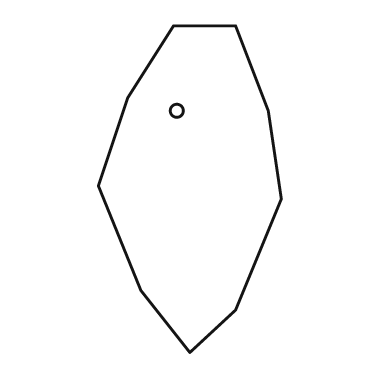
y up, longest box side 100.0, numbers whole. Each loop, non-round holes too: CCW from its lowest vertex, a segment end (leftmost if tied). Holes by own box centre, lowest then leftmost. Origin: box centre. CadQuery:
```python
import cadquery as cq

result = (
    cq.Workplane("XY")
    .moveTo(0.0, -50.0)
    .lineTo(14.0, -37.0)
    .lineTo(28.0, -3.0)
    .lineTo(24.0, 24.0)
    .lineTo(14.0, 50.0)
    .lineTo(-5.0, 50.0)
    .lineTo(-19.0, 28.0)
    .lineTo(-28.0, 1.0)
    .lineTo(-15.0, -31.0)
    .close()
    .moveTo(-4.0, 24.0)
    .circle(2.0)
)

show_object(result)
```